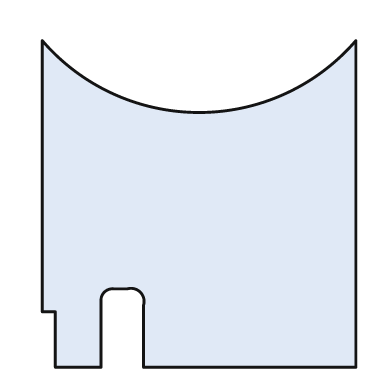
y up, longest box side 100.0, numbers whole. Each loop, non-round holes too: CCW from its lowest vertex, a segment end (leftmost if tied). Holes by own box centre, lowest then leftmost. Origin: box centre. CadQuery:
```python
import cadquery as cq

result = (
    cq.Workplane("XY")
    .moveTo(-44.0, -50.0)
    .lineTo(-30.0, -50.0)
    .lineTo(-30.0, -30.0)
    .threePointArc((-29.0, -27.0), (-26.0, -26.0))
    .lineTo(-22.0, -26.0)
    .threePointArc((-18.0, -27.0), (-17.0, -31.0))
    .lineTo(-17.0, -50.0)
    .lineTo(48.0, -50.0)
    .lineTo(48.0, 50.0)
    .threePointArc((0.0, 28.0), (-48.0, 50.0))
    .lineTo(-48.0, -33.0)
    .lineTo(-44.0, -33.0)
    .close()
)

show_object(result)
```